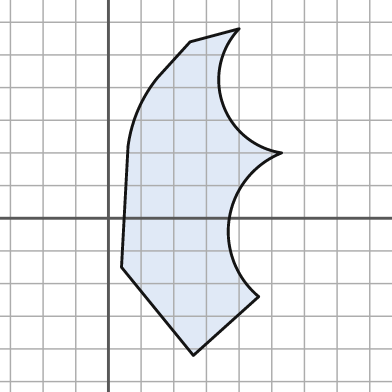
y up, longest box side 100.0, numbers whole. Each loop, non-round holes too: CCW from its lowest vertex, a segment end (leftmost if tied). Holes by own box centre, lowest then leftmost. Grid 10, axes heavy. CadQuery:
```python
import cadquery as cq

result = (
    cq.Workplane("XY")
    .moveTo(26.0, -42.0)
    .lineTo(46.0, -24.0)
    .threePointArc((37.0, 0.0), (53.0, 20.0))
    .threePointArc((35.0, 35.0), (40.0, 58.0))
    .lineTo(25.0, 54.0)
    .lineTo(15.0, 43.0)
    .threePointArc((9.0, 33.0), (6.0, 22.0))
    .lineTo(4.0, -15.0)
    .close()
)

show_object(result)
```